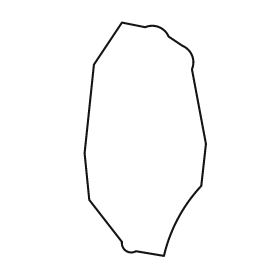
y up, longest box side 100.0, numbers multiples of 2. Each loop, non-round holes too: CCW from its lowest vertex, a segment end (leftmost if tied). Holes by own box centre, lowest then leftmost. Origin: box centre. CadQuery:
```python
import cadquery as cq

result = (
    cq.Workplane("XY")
    .moveTo(8.0, -50.0)
    .threePointArc((14.0, -34.0), (24.0, -20.0))
    .lineTo(26.0, -2.0)
    .lineTo(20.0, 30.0)
    .threePointArc((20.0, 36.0), (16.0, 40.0))
    .lineTo(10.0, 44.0)
    .threePointArc((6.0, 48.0), (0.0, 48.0))
    .lineTo(-10.0, 50.0)
    .lineTo(-22.0, 32.0)
    .lineTo(-26.0, -6.0)
    .lineTo(-24.0, -26.0)
    .lineTo(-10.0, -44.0)
    .threePointArc((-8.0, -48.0), (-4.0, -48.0))
    .close()
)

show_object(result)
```